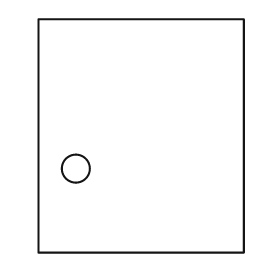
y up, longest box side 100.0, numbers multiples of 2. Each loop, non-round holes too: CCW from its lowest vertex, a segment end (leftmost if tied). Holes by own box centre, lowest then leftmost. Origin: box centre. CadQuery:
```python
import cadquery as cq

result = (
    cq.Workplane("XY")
    .moveTo(-44.0, -50.0)
    .lineTo(44.0, -50.0)
    .lineTo(44.0, 50.0)
    .lineTo(-44.0, 50.0)
    .close()
    .moveTo(-28.0, -14.0)
    .circle(6.0)
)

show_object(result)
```